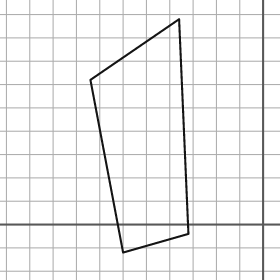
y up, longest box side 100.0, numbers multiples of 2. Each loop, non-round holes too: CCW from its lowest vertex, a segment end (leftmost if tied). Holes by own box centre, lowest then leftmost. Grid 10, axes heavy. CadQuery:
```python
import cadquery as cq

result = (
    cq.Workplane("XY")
    .moveTo(-60.0, -12.0)
    .lineTo(-32.0, -4.0)
    .lineTo(-36.0, 88.0)
    .lineTo(-74.0, 62.0)
    .close()
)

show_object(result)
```